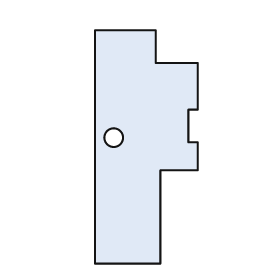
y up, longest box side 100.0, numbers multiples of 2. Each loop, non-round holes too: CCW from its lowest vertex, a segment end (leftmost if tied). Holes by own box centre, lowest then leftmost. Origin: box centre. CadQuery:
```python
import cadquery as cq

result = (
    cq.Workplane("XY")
    .moveTo(-22.0, -50.0)
    .lineTo(6.0, -50.0)
    .lineTo(6.0, -10.0)
    .lineTo(22.0, -10.0)
    .lineTo(22.0, 2.0)
    .lineTo(18.0, 2.0)
    .lineTo(18.0, 16.0)
    .lineTo(22.0, 16.0)
    .lineTo(22.0, 36.0)
    .lineTo(4.0, 36.0)
    .lineTo(4.0, 50.0)
    .lineTo(-22.0, 50.0)
    .close()
    .moveTo(-14.0, 4.0)
    .circle(4.0)
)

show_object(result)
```